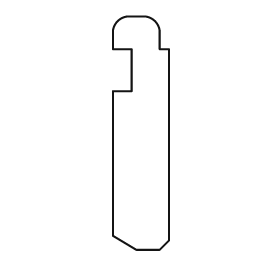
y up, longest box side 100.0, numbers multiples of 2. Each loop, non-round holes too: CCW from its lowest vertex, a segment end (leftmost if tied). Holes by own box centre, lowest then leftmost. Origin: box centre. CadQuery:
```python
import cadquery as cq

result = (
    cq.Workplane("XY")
    .moveTo(-2.0, -50.0)
    .lineTo(8.0, -50.0)
    .lineTo(12.0, -46.0)
    .lineTo(12.0, 36.0)
    .lineTo(8.0, 36.0)
    .lineTo(8.0, 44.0)
    .threePointArc((6.0, 48.0), (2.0, 50.0))
    .lineTo(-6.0, 50.0)
    .threePointArc((-10.0, 48.0), (-12.0, 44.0))
    .lineTo(-12.0, 36.0)
    .lineTo(-4.0, 36.0)
    .lineTo(-4.0, 18.0)
    .lineTo(-12.0, 18.0)
    .lineTo(-12.0, -44.0)
    .close()
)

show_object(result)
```